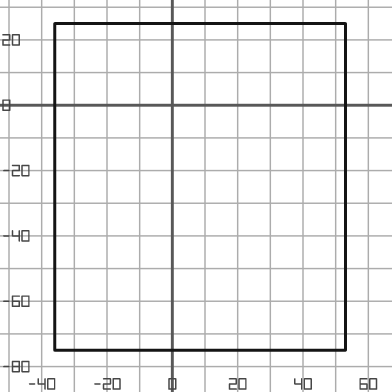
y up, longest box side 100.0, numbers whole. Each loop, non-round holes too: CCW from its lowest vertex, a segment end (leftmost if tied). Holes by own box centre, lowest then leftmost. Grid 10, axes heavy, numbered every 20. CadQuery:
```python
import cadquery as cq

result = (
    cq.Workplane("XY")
    .moveTo(-36.0, -75.0)
    .lineTo(53.0, -75.0)
    .lineTo(53.0, 25.0)
    .lineTo(-36.0, 25.0)
    .close()
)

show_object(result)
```